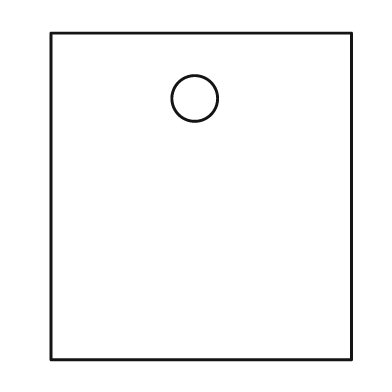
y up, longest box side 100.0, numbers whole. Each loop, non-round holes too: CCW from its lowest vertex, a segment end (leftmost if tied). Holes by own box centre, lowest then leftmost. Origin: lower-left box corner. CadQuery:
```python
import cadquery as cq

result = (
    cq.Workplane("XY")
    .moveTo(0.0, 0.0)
    .lineTo(92.0, 0.0)
    .lineTo(92.0, 100.0)
    .lineTo(0.0, 100.0)
    .close()
    .moveTo(44.0, 80.0)
    .circle(7.0)
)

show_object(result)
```